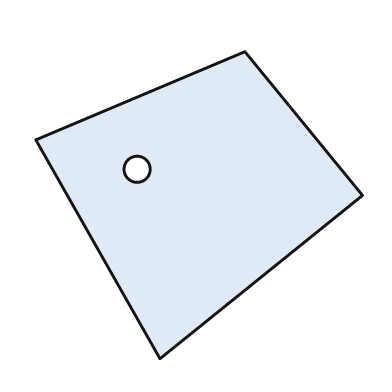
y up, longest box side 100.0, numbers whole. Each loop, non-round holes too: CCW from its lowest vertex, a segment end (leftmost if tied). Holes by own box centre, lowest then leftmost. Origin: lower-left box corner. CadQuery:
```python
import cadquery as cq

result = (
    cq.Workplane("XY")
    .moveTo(38.0, 0.0)
    .lineTo(100.0, 50.0)
    .lineTo(64.0, 94.0)
    .lineTo(0.0, 67.0)
    .close()
    .moveTo(31.0, 58.0)
    .circle(4.0)
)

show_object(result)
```